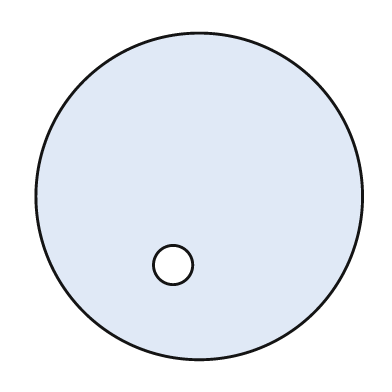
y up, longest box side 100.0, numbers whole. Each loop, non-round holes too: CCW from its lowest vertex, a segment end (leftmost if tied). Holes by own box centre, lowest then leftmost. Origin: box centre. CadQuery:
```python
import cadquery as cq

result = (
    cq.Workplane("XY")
    .moveTo(0.0, 0.0)
    .circle(50.0)
    .moveTo(-8.0, -21.0)
    .circle(6.0)
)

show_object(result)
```